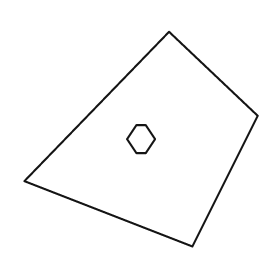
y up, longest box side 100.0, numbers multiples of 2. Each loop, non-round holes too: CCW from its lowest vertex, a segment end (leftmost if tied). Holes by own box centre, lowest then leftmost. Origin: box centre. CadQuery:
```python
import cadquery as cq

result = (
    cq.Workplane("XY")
    .moveTo(22.0, -46.0)
    .lineTo(50.0, 10.0)
    .lineTo(12.0, 46.0)
    .lineTo(-50.0, -18.0)
    .close()
    .moveTo(-2.0, -6.0)
    .lineTo(2.0, -6.0)
    .lineTo(6.0, 0.0)
    .lineTo(2.0, 6.0)
    .lineTo(-2.0, 6.0)
    .lineTo(-6.0, 0.0)
    .close()
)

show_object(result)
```